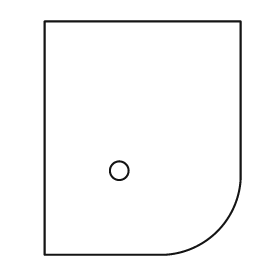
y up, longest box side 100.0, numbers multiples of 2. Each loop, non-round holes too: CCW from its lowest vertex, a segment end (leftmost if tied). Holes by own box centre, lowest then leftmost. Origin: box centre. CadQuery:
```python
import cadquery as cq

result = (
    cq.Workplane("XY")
    .moveTo(-42.0, -50.0)
    .lineTo(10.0, -50.0)
    .threePointArc((32.0, -40.0), (42.0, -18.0))
    .lineTo(42.0, 50.0)
    .lineTo(-42.0, 50.0)
    .close()
    .moveTo(-10.0, -14.0)
    .circle(4.0)
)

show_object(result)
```